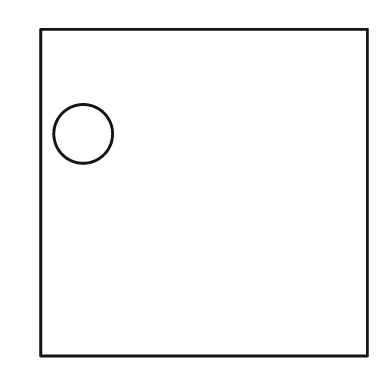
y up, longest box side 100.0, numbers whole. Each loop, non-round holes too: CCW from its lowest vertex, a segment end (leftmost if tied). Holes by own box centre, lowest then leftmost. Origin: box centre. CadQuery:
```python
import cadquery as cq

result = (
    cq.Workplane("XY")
    .moveTo(-50.0, -50.0)
    .lineTo(50.0, -50.0)
    .lineTo(50.0, 50.0)
    .lineTo(-50.0, 50.0)
    .close()
    .moveTo(-37.0, 18.0)
    .circle(9.0)
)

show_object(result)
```